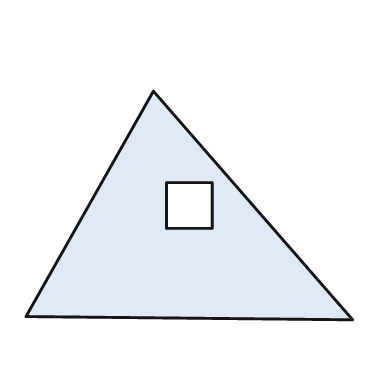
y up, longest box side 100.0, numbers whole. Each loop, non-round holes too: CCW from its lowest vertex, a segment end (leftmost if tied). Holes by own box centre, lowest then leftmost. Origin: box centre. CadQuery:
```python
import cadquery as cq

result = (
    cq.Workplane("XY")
    .moveTo(50.0, -35.0)
    .lineTo(-11.0, 35.0)
    .lineTo(-50.0, -34.0)
    .close()
    .moveTo(-7.0, -7.0)
    .lineTo(7.0, -7.0)
    .lineTo(7.0, 7.0)
    .lineTo(-7.0, 7.0)
    .close()
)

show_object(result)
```